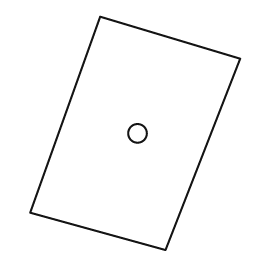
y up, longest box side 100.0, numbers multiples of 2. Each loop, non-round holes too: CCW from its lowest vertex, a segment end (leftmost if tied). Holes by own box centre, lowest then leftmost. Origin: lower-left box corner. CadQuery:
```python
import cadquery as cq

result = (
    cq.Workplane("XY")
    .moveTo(58.0, 0.0)
    .lineTo(90.0, 82.0)
    .lineTo(30.0, 100.0)
    .lineTo(0.0, 16.0)
    .close()
    .moveTo(46.0, 50.0)
    .circle(4.0)
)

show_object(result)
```